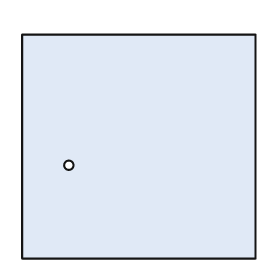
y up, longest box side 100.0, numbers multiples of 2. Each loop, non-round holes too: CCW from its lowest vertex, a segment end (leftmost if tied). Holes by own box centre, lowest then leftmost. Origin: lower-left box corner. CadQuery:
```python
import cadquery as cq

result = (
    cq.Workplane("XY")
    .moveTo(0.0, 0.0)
    .lineTo(100.0, 0.0)
    .lineTo(100.0, 96.0)
    .lineTo(0.0, 96.0)
    .close()
    .moveTo(20.0, 40.0)
    .circle(2.0)
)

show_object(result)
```